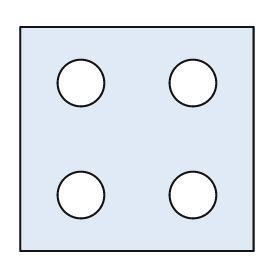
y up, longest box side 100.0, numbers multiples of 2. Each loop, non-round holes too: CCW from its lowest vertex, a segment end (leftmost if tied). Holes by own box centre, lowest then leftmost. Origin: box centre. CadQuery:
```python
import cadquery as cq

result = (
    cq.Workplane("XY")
    .moveTo(-50.0, -48.0)
    .lineTo(50.0, -48.0)
    .lineTo(50.0, 48.0)
    .lineTo(-50.0, 48.0)
    .close()
    .moveTo(-24.0, -24.0)
    .circle(10.0)
    .moveTo(24.0, -24.0)
    .circle(10.0)
    .moveTo(-24.0, 24.0)
    .circle(10.0)
    .moveTo(24.0, 24.0)
    .circle(10.0)
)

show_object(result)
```